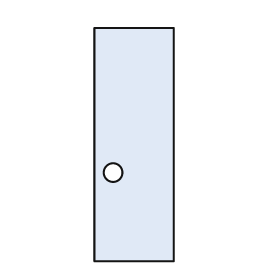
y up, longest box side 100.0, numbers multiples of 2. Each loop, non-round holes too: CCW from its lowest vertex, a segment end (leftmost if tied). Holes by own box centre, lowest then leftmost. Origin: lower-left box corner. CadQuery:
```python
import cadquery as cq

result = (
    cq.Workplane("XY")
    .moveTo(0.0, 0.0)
    .lineTo(34.0, 0.0)
    .lineTo(34.0, 100.0)
    .lineTo(0.0, 100.0)
    .close()
    .moveTo(8.0, 38.0)
    .circle(4.0)
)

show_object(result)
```